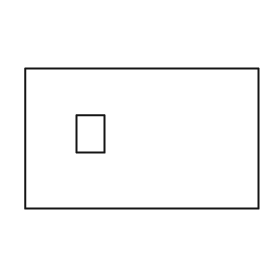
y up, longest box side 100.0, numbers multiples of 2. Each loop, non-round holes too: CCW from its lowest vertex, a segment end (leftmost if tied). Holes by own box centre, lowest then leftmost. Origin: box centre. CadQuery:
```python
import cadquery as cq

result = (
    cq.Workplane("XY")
    .moveTo(-50.0, -30.0)
    .lineTo(50.0, -30.0)
    .lineTo(50.0, 30.0)
    .lineTo(-50.0, 30.0)
    .close()
    .moveTo(-28.0, -6.0)
    .lineTo(-16.0, -6.0)
    .lineTo(-16.0, 10.0)
    .lineTo(-28.0, 10.0)
    .close()
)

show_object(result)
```